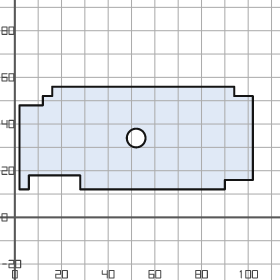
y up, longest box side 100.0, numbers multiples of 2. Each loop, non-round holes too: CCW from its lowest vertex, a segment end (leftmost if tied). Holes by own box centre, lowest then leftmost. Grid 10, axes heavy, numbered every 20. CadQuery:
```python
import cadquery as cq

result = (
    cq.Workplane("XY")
    .moveTo(2.0, 12.0)
    .lineTo(6.0, 12.0)
    .lineTo(6.0, 18.0)
    .lineTo(28.0, 18.0)
    .lineTo(28.0, 12.0)
    .lineTo(90.0, 12.0)
    .lineTo(90.0, 16.0)
    .lineTo(102.0, 16.0)
    .lineTo(102.0, 52.0)
    .lineTo(94.0, 52.0)
    .lineTo(94.0, 56.0)
    .lineTo(16.0, 56.0)
    .lineTo(16.0, 52.0)
    .lineTo(12.0, 52.0)
    .lineTo(12.0, 48.0)
    .lineTo(2.0, 48.0)
    .close()
    .moveTo(52.0, 34.0)
    .circle(4.0)
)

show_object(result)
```